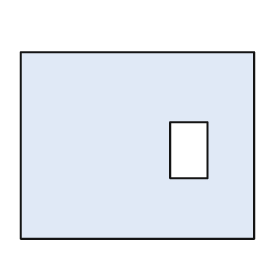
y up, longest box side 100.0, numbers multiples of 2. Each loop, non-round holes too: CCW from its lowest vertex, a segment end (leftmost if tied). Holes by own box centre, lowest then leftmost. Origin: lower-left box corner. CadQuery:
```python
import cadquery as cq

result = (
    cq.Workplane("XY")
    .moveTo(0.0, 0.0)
    .lineTo(100.0, 0.0)
    .lineTo(100.0, 80.0)
    .lineTo(0.0, 80.0)
    .close()
    .moveTo(64.0, 26.0)
    .lineTo(80.0, 26.0)
    .lineTo(80.0, 50.0)
    .lineTo(64.0, 50.0)
    .close()
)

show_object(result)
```